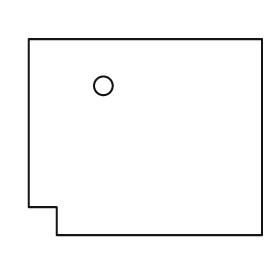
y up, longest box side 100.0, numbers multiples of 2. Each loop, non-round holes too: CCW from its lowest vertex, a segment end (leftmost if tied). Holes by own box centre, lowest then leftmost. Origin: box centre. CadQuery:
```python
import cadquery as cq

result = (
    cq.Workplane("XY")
    .moveTo(-38.0, -42.0)
    .lineTo(50.0, -42.0)
    .lineTo(50.0, 42.0)
    .lineTo(-50.0, 42.0)
    .lineTo(-50.0, -30.0)
    .lineTo(-38.0, -30.0)
    .close()
    .moveTo(-18.0, 22.0)
    .circle(4.0)
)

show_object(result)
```